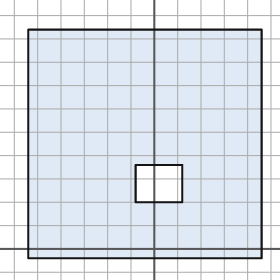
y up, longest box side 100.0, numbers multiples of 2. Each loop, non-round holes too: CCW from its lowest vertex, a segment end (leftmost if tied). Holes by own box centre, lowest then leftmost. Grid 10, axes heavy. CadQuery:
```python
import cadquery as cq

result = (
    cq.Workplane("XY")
    .moveTo(-54.0, -4.0)
    .lineTo(46.0, -4.0)
    .lineTo(46.0, 94.0)
    .lineTo(-54.0, 94.0)
    .close()
    .moveTo(-8.0, 20.0)
    .lineTo(12.0, 20.0)
    .lineTo(12.0, 36.0)
    .lineTo(-8.0, 36.0)
    .close()
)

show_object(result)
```